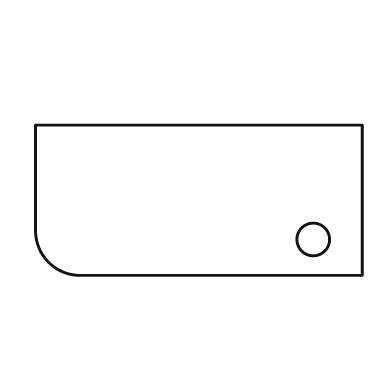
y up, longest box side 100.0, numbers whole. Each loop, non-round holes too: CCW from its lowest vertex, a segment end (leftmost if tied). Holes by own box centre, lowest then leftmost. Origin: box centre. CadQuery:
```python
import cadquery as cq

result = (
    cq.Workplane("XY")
    .moveTo(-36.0, -23.0)
    .lineTo(50.0, -23.0)
    .lineTo(50.0, 23.0)
    .lineTo(-50.0, 23.0)
    .lineTo(-50.0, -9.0)
    .threePointArc((-46.0, -19.0), (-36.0, -23.0))
    .close()
    .moveTo(35.0, -12.0)
    .circle(5.0)
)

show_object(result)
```